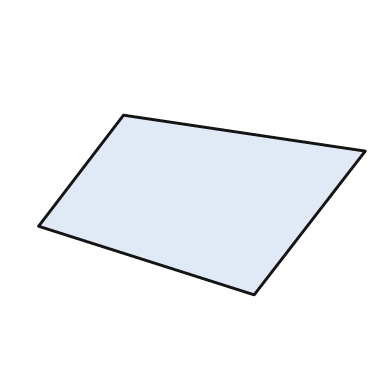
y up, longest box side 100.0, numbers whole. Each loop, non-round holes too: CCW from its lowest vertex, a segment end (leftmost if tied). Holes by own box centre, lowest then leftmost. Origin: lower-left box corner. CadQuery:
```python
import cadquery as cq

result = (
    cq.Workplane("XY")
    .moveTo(66.0, 0.0)
    .lineTo(100.0, 44.0)
    .lineTo(26.0, 55.0)
    .lineTo(0.0, 21.0)
    .close()
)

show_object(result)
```